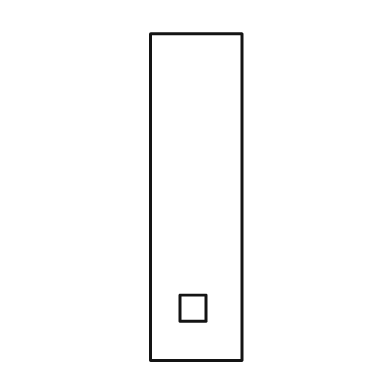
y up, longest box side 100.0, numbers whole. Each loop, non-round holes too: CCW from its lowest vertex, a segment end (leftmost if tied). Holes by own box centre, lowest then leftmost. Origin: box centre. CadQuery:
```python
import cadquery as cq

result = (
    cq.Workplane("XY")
    .moveTo(-14.0, -50.0)
    .lineTo(14.0, -50.0)
    .lineTo(14.0, 50.0)
    .lineTo(-14.0, 50.0)
    .close()
    .moveTo(-5.0, -38.0)
    .lineTo(3.0, -38.0)
    .lineTo(3.0, -30.0)
    .lineTo(-5.0, -30.0)
    .close()
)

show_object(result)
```